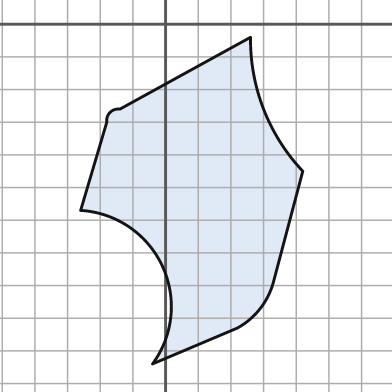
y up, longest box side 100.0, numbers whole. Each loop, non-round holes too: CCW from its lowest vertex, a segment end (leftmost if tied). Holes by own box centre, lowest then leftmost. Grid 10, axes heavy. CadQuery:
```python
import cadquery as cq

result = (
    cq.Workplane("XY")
    .moveTo(-4.0, -104.0)
    .lineTo(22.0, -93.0)
    .threePointArc((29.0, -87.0), (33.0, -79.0))
    .lineTo(42.0, -45.0)
    .threePointArc((30.0, -26.0), (26.0, -4.0))
    .lineTo(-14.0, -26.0)
    .threePointArc((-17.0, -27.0), (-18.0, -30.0))
    .lineTo(-26.0, -57.0)
    .threePointArc((-1.0, -74.0), (-4.0, -104.0))
    .close()
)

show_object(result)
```